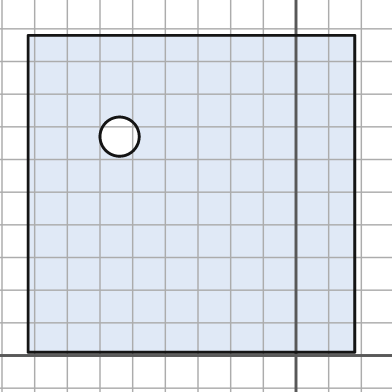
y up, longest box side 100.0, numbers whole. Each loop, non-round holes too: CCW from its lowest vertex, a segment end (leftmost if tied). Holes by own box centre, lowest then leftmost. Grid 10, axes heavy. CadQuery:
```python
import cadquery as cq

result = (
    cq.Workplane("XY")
    .moveTo(-82.0, 1.0)
    .lineTo(18.0, 1.0)
    .lineTo(18.0, 98.0)
    .lineTo(-82.0, 98.0)
    .close()
    .moveTo(-54.0, 67.0)
    .circle(6.0)
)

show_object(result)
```